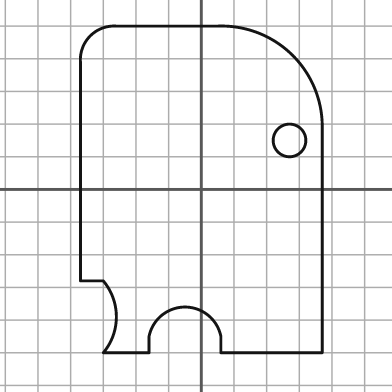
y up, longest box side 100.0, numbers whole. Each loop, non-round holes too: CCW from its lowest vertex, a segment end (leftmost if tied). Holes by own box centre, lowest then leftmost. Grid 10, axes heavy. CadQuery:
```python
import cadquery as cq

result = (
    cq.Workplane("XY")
    .moveTo(-30.0, -50.0)
    .lineTo(-16.0, -50.0)
    .lineTo(-16.0, -45.0)
    .threePointArc((-5.0, -36.0), (6.0, -45.0))
    .lineTo(6.0, -50.0)
    .lineTo(37.0, -50.0)
    .lineTo(37.0, 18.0)
    .threePointArc((28.0, 41.0), (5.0, 50.0))
    .lineTo(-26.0, 50.0)
    .threePointArc((-34.0, 47.0), (-37.0, 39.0))
    .lineTo(-37.0, -28.0)
    .lineTo(-30.0, -28.0)
    .threePointArc((-26.0, -39.0), (-30.0, -50.0))
    .close()
    .moveTo(27.0, 15.0)
    .circle(5.0)
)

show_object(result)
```